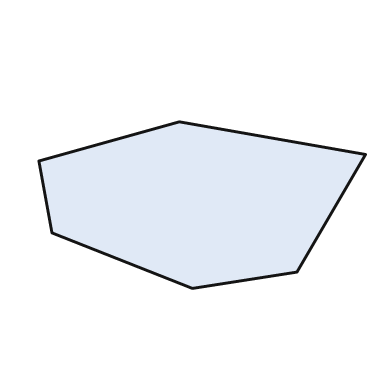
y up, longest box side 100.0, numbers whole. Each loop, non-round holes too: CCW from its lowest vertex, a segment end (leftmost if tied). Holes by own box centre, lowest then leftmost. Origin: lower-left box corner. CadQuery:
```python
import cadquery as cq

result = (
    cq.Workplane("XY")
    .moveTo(47.0, 0.0)
    .lineTo(79.0, 5.0)
    .lineTo(100.0, 41.0)
    .lineTo(43.0, 51.0)
    .lineTo(0.0, 39.0)
    .lineTo(4.0, 17.0)
    .close()
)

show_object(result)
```